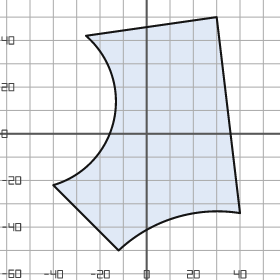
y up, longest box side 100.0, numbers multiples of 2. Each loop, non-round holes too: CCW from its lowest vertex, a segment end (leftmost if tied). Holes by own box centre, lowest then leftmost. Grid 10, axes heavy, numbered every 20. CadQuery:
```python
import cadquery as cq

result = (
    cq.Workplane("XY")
    .moveTo(-12.0, -50.0)
    .threePointArc((12.0, -36.0), (40.0, -34.0))
    .lineTo(30.0, 50.0)
    .lineTo(-26.0, 42.0)
    .threePointArc((-14.0, 6.0), (-40.0, -22.0))
    .close()
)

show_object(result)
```